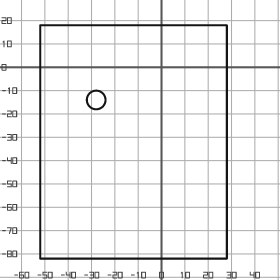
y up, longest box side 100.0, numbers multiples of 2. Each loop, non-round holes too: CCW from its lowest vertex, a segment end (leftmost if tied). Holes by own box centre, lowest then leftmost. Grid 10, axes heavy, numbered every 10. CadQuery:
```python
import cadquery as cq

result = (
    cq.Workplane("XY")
    .moveTo(-52.0, -82.0)
    .lineTo(28.0, -82.0)
    .lineTo(28.0, 18.0)
    .lineTo(-52.0, 18.0)
    .close()
    .moveTo(-28.0, -14.0)
    .circle(4.0)
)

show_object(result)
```